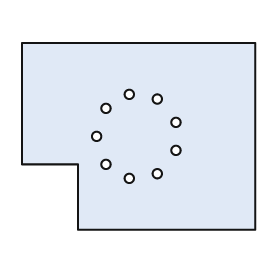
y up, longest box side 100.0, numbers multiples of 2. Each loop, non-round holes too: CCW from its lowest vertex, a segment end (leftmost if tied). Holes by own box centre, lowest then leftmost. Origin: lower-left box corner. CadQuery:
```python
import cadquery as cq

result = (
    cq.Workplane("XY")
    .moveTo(24.0, 0.0)
    .lineTo(100.0, 0.0)
    .lineTo(100.0, 80.0)
    .lineTo(0.0, 80.0)
    .lineTo(0.0, 28.0)
    .lineTo(24.0, 28.0)
    .close()
    .moveTo(46.0, 22.0)
    .circle(2.0)
    .moveTo(58.0, 24.0)
    .circle(2.0)
    .moveTo(36.0, 28.0)
    .circle(2.0)
    .moveTo(66.0, 34.0)
    .circle(2.0)
    .moveTo(32.0, 40.0)
    .circle(2.0)
    .moveTo(66.0, 46.0)
    .circle(2.0)
    .moveTo(36.0, 52.0)
    .circle(2.0)
    .moveTo(58.0, 56.0)
    .circle(2.0)
    .moveTo(46.0, 58.0)
    .circle(2.0)
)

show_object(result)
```